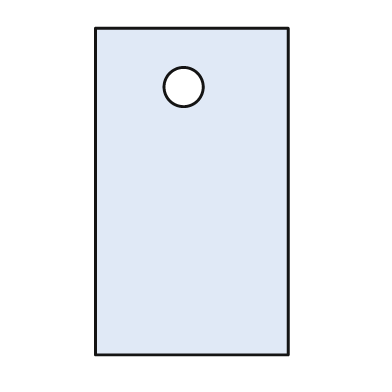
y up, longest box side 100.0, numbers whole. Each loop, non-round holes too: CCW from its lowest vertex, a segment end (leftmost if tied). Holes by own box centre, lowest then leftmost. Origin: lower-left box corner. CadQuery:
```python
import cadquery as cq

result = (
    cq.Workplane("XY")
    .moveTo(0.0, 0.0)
    .lineTo(59.0, 0.0)
    .lineTo(59.0, 100.0)
    .lineTo(0.0, 100.0)
    .close()
    .moveTo(27.0, 82.0)
    .circle(6.0)
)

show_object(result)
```